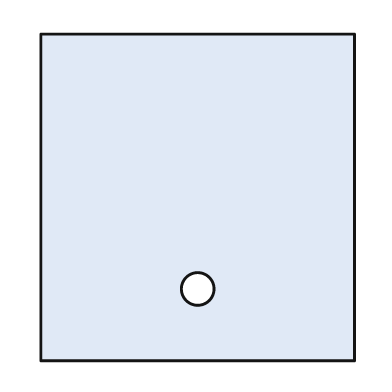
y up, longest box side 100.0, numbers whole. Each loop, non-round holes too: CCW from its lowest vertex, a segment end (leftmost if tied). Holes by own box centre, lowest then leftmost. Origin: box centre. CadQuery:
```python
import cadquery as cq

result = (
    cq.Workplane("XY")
    .moveTo(-48.0, -50.0)
    .lineTo(48.0, -50.0)
    .lineTo(48.0, 50.0)
    .lineTo(-48.0, 50.0)
    .close()
    .moveTo(0.0, -28.0)
    .circle(5.0)
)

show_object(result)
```